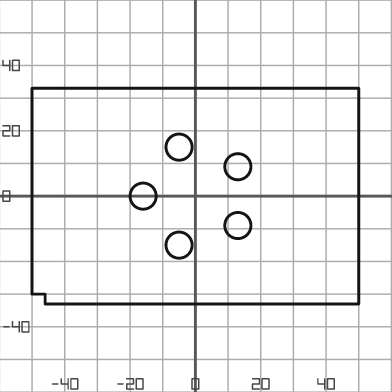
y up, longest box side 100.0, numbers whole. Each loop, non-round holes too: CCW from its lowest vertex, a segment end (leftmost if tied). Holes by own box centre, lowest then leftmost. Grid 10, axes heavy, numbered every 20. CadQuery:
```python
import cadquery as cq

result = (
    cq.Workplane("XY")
    .moveTo(-46.0, -33.0)
    .lineTo(50.0, -33.0)
    .lineTo(50.0, 33.0)
    .lineTo(-50.0, 33.0)
    .lineTo(-50.0, -30.0)
    .lineTo(-46.0, -30.0)
    .close()
    .moveTo(-5.0, -15.0)
    .circle(4.0)
    .moveTo(13.0, -9.0)
    .circle(4.0)
    .moveTo(-16.0, 0.0)
    .circle(4.0)
    .moveTo(13.0, 9.0)
    .circle(4.0)
    .moveTo(-5.0, 15.0)
    .circle(4.0)
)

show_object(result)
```